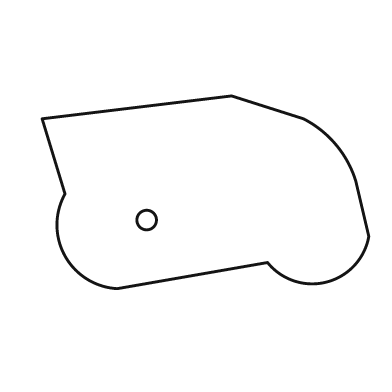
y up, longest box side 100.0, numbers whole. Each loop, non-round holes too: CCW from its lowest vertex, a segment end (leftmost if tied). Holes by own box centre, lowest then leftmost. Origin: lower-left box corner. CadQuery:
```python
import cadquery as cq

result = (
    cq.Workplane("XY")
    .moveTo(23.0, 0.0)
    .lineTo(69.0, 8.0)
    .threePointArc((87.0, 2.0), (100.0, 16.0))
    .lineTo(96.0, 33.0)
    .threePointArc((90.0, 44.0), (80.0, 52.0))
    .lineTo(58.0, 59.0)
    .lineTo(0.0, 52.0)
    .lineTo(7.0, 29.0)
    .threePointArc((7.0, 10.0), (23.0, 0.0))
    .close()
    .moveTo(32.0, 21.0)
    .circle(3.0)
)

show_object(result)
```